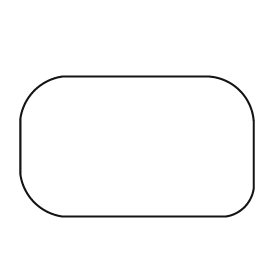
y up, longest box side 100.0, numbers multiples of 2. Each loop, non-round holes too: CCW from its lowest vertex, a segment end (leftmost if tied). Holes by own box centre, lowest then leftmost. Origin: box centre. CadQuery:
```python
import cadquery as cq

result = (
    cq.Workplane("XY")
    .moveTo(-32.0, -30.0)
    .lineTo(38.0, -30.0)
    .threePointArc((46.0, -26.0), (50.0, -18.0))
    .lineTo(50.0, 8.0)
    .threePointArc((44.0, 24.0), (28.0, 30.0))
    .lineTo(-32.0, 30.0)
    .threePointArc((-44.0, 24.0), (-50.0, 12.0))
    .lineTo(-50.0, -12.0)
    .threePointArc((-44.0, -24.0), (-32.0, -30.0))
    .close()
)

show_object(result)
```